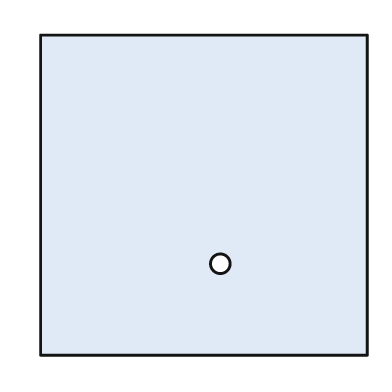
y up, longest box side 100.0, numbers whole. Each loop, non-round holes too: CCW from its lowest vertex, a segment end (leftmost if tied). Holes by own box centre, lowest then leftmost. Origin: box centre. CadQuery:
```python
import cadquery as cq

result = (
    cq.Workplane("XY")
    .moveTo(-50.0, -49.0)
    .lineTo(50.0, -49.0)
    .lineTo(50.0, 49.0)
    .lineTo(-50.0, 49.0)
    .close()
    .moveTo(5.0, -21.0)
    .circle(3.0)
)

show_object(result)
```